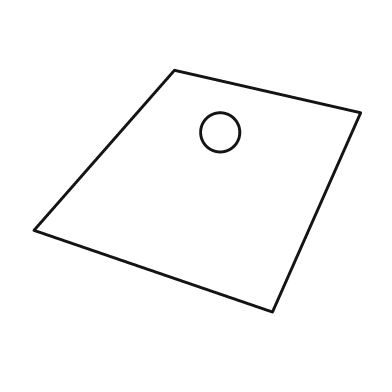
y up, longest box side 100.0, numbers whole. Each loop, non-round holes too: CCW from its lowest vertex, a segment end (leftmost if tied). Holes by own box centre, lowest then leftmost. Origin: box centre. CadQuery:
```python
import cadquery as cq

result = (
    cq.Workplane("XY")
    .moveTo(23.0, -37.0)
    .lineTo(50.0, 24.0)
    .lineTo(-7.0, 37.0)
    .lineTo(-50.0, -12.0)
    .close()
    .moveTo(7.0, 18.0)
    .circle(6.0)
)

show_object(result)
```